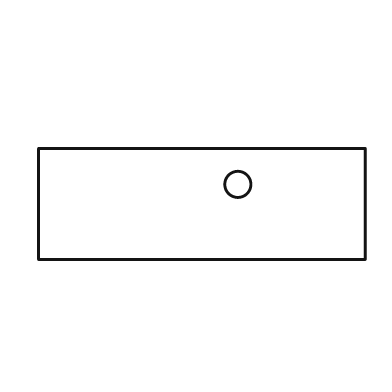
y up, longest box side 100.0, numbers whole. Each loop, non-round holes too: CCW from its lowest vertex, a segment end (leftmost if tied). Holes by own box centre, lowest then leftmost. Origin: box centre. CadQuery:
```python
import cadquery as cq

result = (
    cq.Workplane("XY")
    .moveTo(-50.0, -17.0)
    .lineTo(50.0, -17.0)
    .lineTo(50.0, 17.0)
    .lineTo(-50.0, 17.0)
    .close()
    .moveTo(11.0, 6.0)
    .circle(4.0)
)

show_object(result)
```